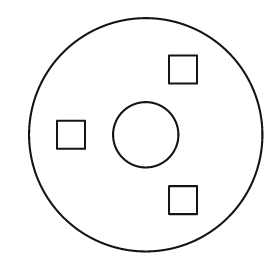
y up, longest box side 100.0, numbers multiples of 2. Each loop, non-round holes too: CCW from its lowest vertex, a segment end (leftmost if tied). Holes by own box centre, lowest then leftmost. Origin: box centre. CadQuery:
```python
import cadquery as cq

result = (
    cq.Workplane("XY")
    .moveTo(0.0, 0.0)
    .circle(50.0)
    .moveTo(10.0, -34.0)
    .lineTo(22.0, -34.0)
    .lineTo(22.0, -22.0)
    .lineTo(10.0, -22.0)
    .close()
    .moveTo(-38.0, -6.0)
    .lineTo(-26.0, -6.0)
    .lineTo(-26.0, 6.0)
    .lineTo(-38.0, 6.0)
    .close()
    .moveTo(0.0, 0.0)
    .circle(14.0)
    .moveTo(10.0, 22.0)
    .lineTo(22.0, 22.0)
    .lineTo(22.0, 34.0)
    .lineTo(10.0, 34.0)
    .close()
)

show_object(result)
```